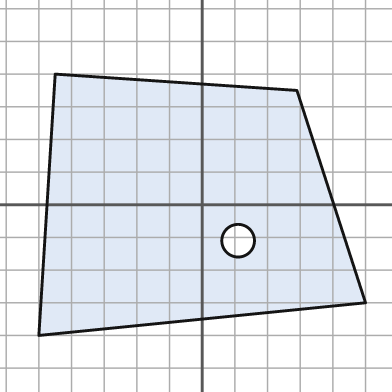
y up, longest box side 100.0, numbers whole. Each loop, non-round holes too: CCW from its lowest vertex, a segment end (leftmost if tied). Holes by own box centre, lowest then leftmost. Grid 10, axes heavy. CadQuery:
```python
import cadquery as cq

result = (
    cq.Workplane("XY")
    .moveTo(-50.0, -40.0)
    .lineTo(50.0, -30.0)
    .lineTo(29.0, 35.0)
    .lineTo(-45.0, 40.0)
    .close()
    .moveTo(11.0, -11.0)
    .circle(5.0)
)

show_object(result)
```